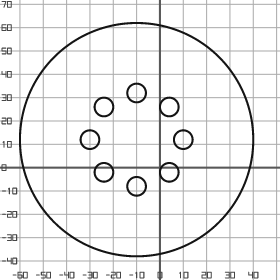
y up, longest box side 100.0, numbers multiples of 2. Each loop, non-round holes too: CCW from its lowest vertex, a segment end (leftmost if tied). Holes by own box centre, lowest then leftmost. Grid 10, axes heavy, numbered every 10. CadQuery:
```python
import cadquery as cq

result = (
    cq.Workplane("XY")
    .moveTo(-10.0, 12.0)
    .circle(50.0)
    .moveTo(-10.0, -8.0)
    .circle(4.0)
    .moveTo(-24.0, -2.0)
    .circle(4.0)
    .moveTo(4.0, -2.0)
    .circle(4.0)
    .moveTo(-30.0, 12.0)
    .circle(4.0)
    .moveTo(10.0, 12.0)
    .circle(4.0)
    .moveTo(-24.0, 26.0)
    .circle(4.0)
    .moveTo(4.0, 26.0)
    .circle(4.0)
    .moveTo(-10.0, 32.0)
    .circle(4.0)
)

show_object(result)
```